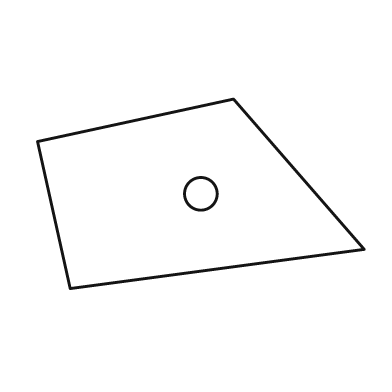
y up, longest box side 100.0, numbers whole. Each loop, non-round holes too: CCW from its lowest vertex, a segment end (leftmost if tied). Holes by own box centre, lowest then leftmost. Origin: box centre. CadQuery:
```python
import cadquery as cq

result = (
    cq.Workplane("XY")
    .moveTo(-40.0, -29.0)
    .lineTo(50.0, -17.0)
    .lineTo(10.0, 29.0)
    .lineTo(-50.0, 16.0)
    .close()
    .moveTo(0.0, 0.0)
    .circle(5.0)
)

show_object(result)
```